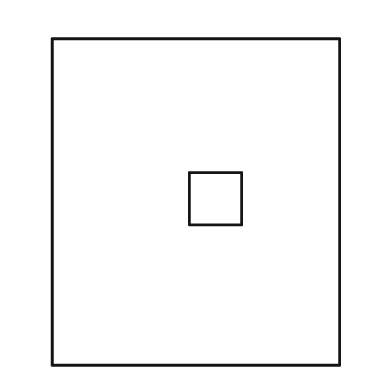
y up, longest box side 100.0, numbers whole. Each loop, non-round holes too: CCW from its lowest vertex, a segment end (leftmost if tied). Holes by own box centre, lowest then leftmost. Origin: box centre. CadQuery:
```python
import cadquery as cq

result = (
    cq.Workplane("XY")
    .moveTo(-44.0, -50.0)
    .lineTo(44.0, -50.0)
    .lineTo(44.0, 50.0)
    .lineTo(-44.0, 50.0)
    .close()
    .moveTo(-2.0, -7.0)
    .lineTo(14.0, -7.0)
    .lineTo(14.0, 9.0)
    .lineTo(-2.0, 9.0)
    .close()
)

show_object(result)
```